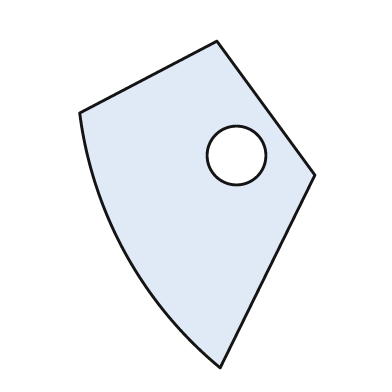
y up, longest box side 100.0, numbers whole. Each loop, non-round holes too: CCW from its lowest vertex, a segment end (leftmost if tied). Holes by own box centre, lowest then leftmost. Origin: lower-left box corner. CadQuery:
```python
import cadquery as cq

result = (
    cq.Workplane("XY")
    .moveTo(43.0, 0.0)
    .lineTo(72.0, 59.0)
    .lineTo(42.0, 100.0)
    .lineTo(0.0, 78.0)
    .threePointArc((14.0, 35.0), (43.0, 0.0))
    .close()
    .moveTo(48.0, 65.0)
    .circle(9.0)
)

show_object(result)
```